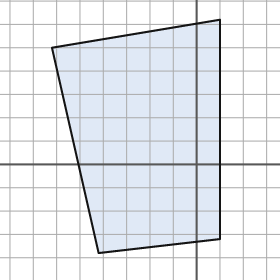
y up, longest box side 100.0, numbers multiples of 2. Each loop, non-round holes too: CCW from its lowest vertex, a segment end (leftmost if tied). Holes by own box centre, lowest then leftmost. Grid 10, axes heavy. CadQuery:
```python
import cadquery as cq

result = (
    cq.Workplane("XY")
    .moveTo(-42.0, -38.0)
    .lineTo(10.0, -32.0)
    .lineTo(10.0, 62.0)
    .lineTo(-62.0, 50.0)
    .close()
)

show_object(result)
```